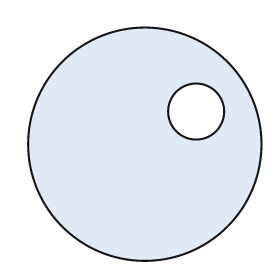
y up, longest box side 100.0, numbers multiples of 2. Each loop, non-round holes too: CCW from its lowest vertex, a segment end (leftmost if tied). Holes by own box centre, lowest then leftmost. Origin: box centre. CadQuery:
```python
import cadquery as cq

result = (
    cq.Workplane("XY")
    .moveTo(0.0, 0.0)
    .circle(50.0)
    .moveTo(22.0, 14.0)
    .circle(12.0)
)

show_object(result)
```